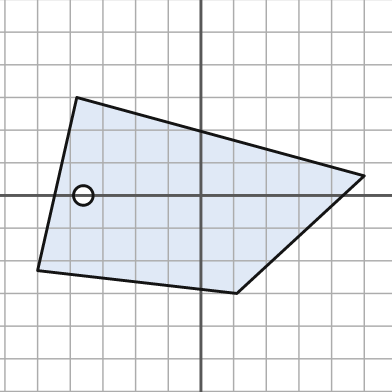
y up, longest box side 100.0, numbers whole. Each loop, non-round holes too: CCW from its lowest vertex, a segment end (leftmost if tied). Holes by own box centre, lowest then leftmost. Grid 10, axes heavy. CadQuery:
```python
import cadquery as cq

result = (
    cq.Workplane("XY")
    .moveTo(11.0, -30.0)
    .lineTo(50.0, 6.0)
    .lineTo(-38.0, 30.0)
    .lineTo(-50.0, -23.0)
    .close()
    .moveTo(-36.0, 0.0)
    .circle(3.0)
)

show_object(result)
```